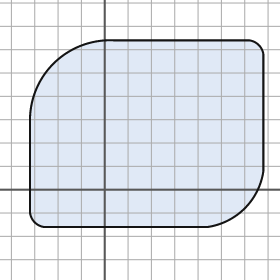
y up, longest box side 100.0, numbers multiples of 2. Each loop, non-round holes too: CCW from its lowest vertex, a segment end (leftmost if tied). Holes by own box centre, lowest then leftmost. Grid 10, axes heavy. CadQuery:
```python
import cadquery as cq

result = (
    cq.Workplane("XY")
    .moveTo(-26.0, -16.0)
    .lineTo(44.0, -16.0)
    .threePointArc((60.0, -8.0), (68.0, 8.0))
    .lineTo(68.0, 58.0)
    .threePointArc((66.0, 62.0), (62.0, 64.0))
    .lineTo(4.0, 64.0)
    .threePointArc((-22.0, 54.0), (-32.0, 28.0))
    .lineTo(-32.0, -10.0)
    .threePointArc((-30.0, -14.0), (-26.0, -16.0))
    .close()
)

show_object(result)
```